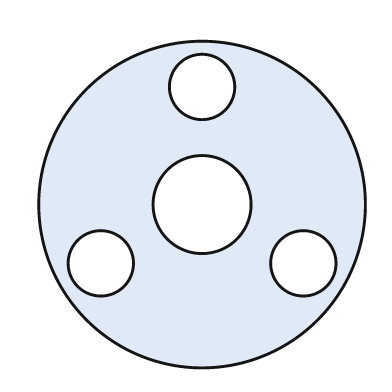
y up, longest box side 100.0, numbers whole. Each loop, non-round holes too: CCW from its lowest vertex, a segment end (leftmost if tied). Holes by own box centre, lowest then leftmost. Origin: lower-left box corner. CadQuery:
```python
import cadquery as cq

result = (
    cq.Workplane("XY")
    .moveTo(50.0, 50.0)
    .circle(50.0)
    .moveTo(19.0, 32.0)
    .circle(10.0)
    .moveTo(81.0, 32.0)
    .circle(10.0)
    .moveTo(50.0, 50.0)
    .circle(15.0)
    .moveTo(50.0, 86.0)
    .circle(10.0)
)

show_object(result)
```